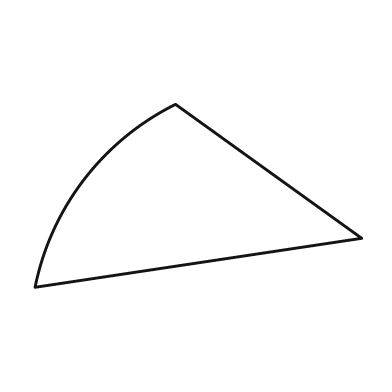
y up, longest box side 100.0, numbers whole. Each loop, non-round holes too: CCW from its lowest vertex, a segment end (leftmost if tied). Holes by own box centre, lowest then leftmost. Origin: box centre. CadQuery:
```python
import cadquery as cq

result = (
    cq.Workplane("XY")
    .moveTo(-50.0, -28.0)
    .lineTo(50.0, -13.0)
    .lineTo(-7.0, 28.0)
    .threePointArc((-35.0, 5.0), (-50.0, -28.0))
    .close()
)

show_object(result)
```